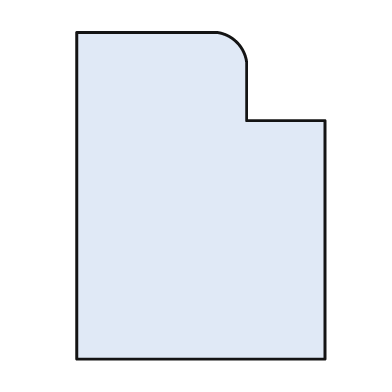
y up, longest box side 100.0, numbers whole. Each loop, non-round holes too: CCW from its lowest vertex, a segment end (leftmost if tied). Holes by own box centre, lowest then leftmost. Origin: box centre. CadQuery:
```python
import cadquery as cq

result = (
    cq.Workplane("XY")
    .moveTo(-38.0, -50.0)
    .lineTo(38.0, -50.0)
    .lineTo(38.0, 23.0)
    .lineTo(14.0, 23.0)
    .lineTo(14.0, 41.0)
    .threePointArc((11.0, 47.0), (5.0, 50.0))
    .lineTo(-38.0, 50.0)
    .close()
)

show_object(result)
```